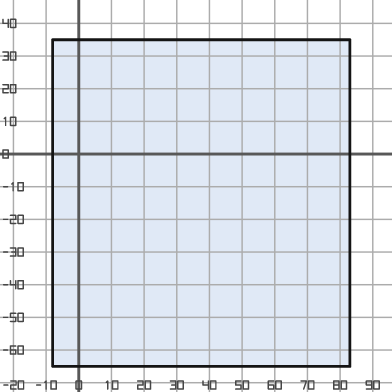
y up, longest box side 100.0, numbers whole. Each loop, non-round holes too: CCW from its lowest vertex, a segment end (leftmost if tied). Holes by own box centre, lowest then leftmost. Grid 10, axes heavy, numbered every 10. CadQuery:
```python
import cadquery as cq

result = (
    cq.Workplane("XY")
    .moveTo(-8.0, -65.0)
    .lineTo(83.0, -65.0)
    .lineTo(83.0, 35.0)
    .lineTo(-8.0, 35.0)
    .close()
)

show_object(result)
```